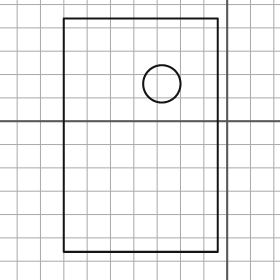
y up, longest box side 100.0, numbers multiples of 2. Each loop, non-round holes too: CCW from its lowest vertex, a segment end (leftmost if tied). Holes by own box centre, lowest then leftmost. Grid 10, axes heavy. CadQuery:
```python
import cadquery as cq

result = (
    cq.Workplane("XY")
    .moveTo(-70.0, -56.0)
    .lineTo(-4.0, -56.0)
    .lineTo(-4.0, 44.0)
    .lineTo(-70.0, 44.0)
    .close()
    .moveTo(-28.0, 16.0)
    .circle(8.0)
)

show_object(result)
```